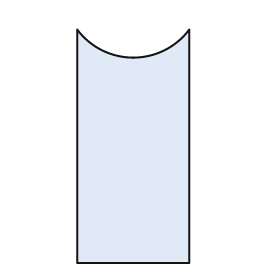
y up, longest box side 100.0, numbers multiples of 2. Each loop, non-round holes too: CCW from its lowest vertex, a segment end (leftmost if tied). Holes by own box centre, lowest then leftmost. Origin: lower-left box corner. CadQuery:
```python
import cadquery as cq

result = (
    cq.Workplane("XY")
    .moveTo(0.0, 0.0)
    .lineTo(48.0, 0.0)
    .lineTo(48.0, 100.0)
    .threePointArc((24.0, 88.0), (0.0, 100.0))
    .close()
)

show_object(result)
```